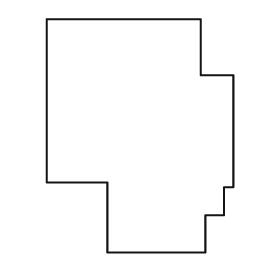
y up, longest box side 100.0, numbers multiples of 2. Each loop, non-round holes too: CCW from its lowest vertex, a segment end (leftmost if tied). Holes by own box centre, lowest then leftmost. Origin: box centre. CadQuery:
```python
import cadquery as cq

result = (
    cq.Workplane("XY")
    .moveTo(-14.0, -50.0)
    .lineTo(28.0, -50.0)
    .lineTo(28.0, -34.0)
    .lineTo(36.0, -34.0)
    .lineTo(36.0, -22.0)
    .lineTo(40.0, -22.0)
    .lineTo(40.0, 26.0)
    .lineTo(26.0, 26.0)
    .lineTo(26.0, 50.0)
    .lineTo(-40.0, 50.0)
    .lineTo(-40.0, -20.0)
    .lineTo(-14.0, -20.0)
    .close()
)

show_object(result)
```